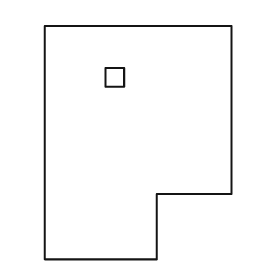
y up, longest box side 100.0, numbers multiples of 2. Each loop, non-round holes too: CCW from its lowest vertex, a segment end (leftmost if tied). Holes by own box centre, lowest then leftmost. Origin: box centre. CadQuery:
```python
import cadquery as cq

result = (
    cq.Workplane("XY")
    .moveTo(-40.0, -50.0)
    .lineTo(8.0, -50.0)
    .lineTo(8.0, -22.0)
    .lineTo(40.0, -22.0)
    .lineTo(40.0, 50.0)
    .lineTo(-40.0, 50.0)
    .close()
    .moveTo(-14.0, 24.0)
    .lineTo(-6.0, 24.0)
    .lineTo(-6.0, 32.0)
    .lineTo(-14.0, 32.0)
    .close()
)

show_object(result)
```